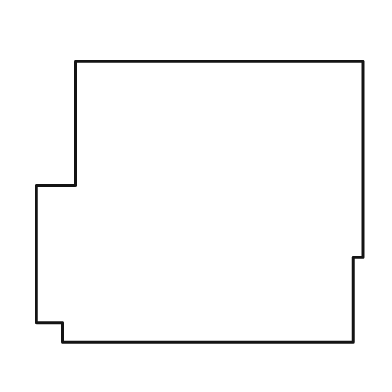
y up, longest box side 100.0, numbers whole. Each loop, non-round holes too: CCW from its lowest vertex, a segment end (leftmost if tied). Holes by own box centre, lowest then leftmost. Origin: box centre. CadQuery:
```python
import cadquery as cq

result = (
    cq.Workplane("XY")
    .moveTo(-42.0, -43.0)
    .lineTo(47.0, -43.0)
    .lineTo(47.0, -17.0)
    .lineTo(50.0, -17.0)
    .lineTo(50.0, 43.0)
    .lineTo(-38.0, 43.0)
    .lineTo(-38.0, 5.0)
    .lineTo(-50.0, 5.0)
    .lineTo(-50.0, -37.0)
    .lineTo(-42.0, -37.0)
    .close()
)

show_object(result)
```